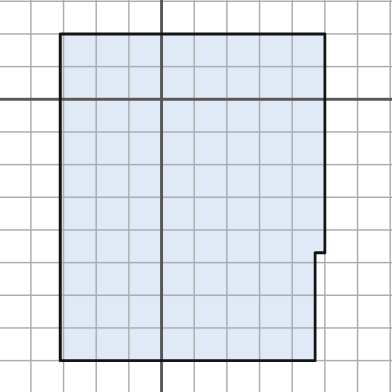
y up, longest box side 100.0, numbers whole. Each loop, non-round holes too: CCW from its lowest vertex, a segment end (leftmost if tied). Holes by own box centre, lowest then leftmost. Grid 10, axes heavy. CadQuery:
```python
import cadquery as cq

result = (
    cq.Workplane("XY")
    .moveTo(-31.0, -80.0)
    .lineTo(47.0, -80.0)
    .lineTo(47.0, -47.0)
    .lineTo(50.0, -47.0)
    .lineTo(50.0, 20.0)
    .lineTo(-31.0, 20.0)
    .close()
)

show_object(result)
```